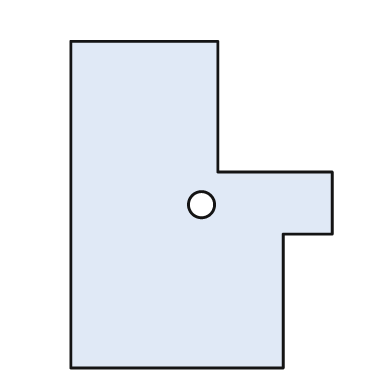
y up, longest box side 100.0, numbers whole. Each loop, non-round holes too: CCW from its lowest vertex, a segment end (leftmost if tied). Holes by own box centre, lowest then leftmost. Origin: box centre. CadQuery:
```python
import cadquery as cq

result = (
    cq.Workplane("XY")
    .moveTo(-40.0, -50.0)
    .lineTo(25.0, -50.0)
    .lineTo(25.0, -9.0)
    .lineTo(40.0, -9.0)
    .lineTo(40.0, 10.0)
    .lineTo(5.0, 10.0)
    .lineTo(5.0, 50.0)
    .lineTo(-40.0, 50.0)
    .close()
    .moveTo(0.0, 0.0)
    .circle(4.0)
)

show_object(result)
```